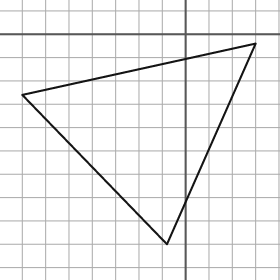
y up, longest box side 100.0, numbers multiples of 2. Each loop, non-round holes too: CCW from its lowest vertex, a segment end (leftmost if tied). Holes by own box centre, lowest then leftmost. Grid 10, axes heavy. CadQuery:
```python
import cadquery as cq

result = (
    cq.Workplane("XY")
    .moveTo(-8.0, -90.0)
    .lineTo(30.0, -4.0)
    .lineTo(-70.0, -26.0)
    .close()
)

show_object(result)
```